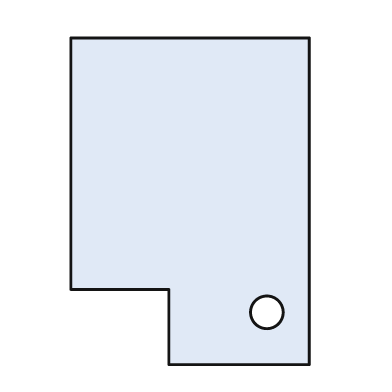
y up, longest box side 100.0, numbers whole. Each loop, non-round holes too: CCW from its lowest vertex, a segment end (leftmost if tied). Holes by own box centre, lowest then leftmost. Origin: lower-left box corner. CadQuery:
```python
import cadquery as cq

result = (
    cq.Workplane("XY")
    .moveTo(30.0, 0.0)
    .lineTo(73.0, 0.0)
    .lineTo(73.0, 100.0)
    .lineTo(0.0, 100.0)
    .lineTo(0.0, 23.0)
    .lineTo(30.0, 23.0)
    .close()
    .moveTo(60.0, 16.0)
    .circle(5.0)
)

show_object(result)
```